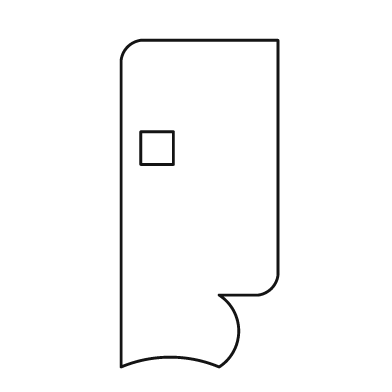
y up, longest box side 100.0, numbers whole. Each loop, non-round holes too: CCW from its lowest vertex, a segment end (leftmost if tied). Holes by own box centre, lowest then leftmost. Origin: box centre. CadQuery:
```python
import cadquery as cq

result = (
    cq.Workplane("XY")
    .moveTo(-24.0, -50.0)
    .threePointArc((-9.0, -47.0), (6.0, -50.0))
    .threePointArc((12.0, -39.0), (6.0, -28.0))
    .lineTo(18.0, -28.0)
    .threePointArc((22.0, -26.0), (24.0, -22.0))
    .lineTo(24.0, 50.0)
    .lineTo(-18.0, 50.0)
    .threePointArc((-22.0, 48.0), (-24.0, 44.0))
    .close()
    .moveTo(-18.0, 12.0)
    .lineTo(-8.0, 12.0)
    .lineTo(-8.0, 22.0)
    .lineTo(-18.0, 22.0)
    .close()
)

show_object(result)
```